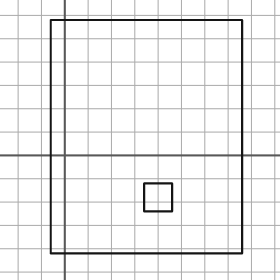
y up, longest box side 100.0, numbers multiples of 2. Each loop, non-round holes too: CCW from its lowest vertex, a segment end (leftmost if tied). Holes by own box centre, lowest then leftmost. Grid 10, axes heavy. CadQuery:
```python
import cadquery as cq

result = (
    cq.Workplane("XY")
    .moveTo(-6.0, -42.0)
    .lineTo(76.0, -42.0)
    .lineTo(76.0, 58.0)
    .lineTo(-6.0, 58.0)
    .close()
    .moveTo(34.0, -24.0)
    .lineTo(46.0, -24.0)
    .lineTo(46.0, -12.0)
    .lineTo(34.0, -12.0)
    .close()
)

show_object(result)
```